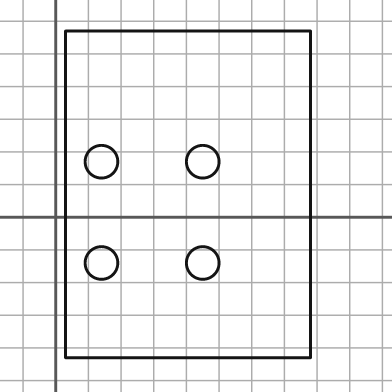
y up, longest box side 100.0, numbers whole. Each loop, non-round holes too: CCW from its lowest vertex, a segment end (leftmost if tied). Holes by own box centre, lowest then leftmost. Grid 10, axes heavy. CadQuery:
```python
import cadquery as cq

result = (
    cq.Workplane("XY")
    .moveTo(3.0, -43.0)
    .lineTo(78.0, -43.0)
    .lineTo(78.0, 57.0)
    .lineTo(3.0, 57.0)
    .close()
    .moveTo(14.0, -14.0)
    .circle(5.0)
    .moveTo(45.0, -14.0)
    .circle(5.0)
    .moveTo(14.0, 17.0)
    .circle(5.0)
    .moveTo(45.0, 17.0)
    .circle(5.0)
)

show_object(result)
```